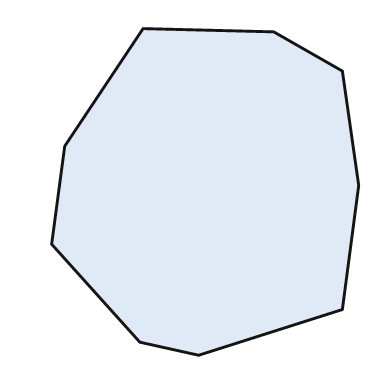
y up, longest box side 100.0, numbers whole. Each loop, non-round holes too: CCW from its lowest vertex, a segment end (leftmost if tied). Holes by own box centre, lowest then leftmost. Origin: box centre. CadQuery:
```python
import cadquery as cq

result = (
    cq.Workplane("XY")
    .moveTo(-2.0, -50.0)
    .lineTo(42.0, -36.0)
    .lineTo(47.0, 2.0)
    .lineTo(42.0, 37.0)
    .lineTo(21.0, 49.0)
    .lineTo(-19.0, 50.0)
    .lineTo(-43.0, 14.0)
    .lineTo(-47.0, -16.0)
    .lineTo(-20.0, -46.0)
    .close()
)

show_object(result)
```